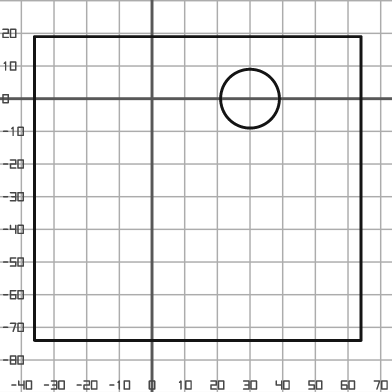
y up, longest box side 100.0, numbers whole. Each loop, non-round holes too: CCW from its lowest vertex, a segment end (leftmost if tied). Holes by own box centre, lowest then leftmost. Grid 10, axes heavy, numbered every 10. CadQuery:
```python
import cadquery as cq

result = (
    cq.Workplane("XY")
    .moveTo(-36.0, -74.0)
    .lineTo(64.0, -74.0)
    .lineTo(64.0, 19.0)
    .lineTo(-36.0, 19.0)
    .close()
    .moveTo(30.0, 0.0)
    .circle(9.0)
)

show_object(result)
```